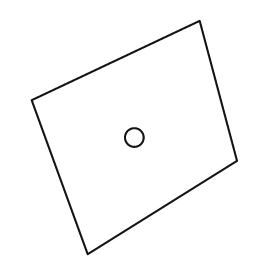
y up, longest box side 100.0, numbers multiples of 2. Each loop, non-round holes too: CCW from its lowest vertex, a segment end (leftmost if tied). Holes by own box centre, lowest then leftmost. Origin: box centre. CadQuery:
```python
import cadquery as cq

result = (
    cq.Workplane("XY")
    .moveTo(-20.0, -50.0)
    .lineTo(44.0, -10.0)
    .lineTo(28.0, 50.0)
    .lineTo(-44.0, 16.0)
    .close()
    .moveTo(0.0, 0.0)
    .circle(4.0)
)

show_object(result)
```